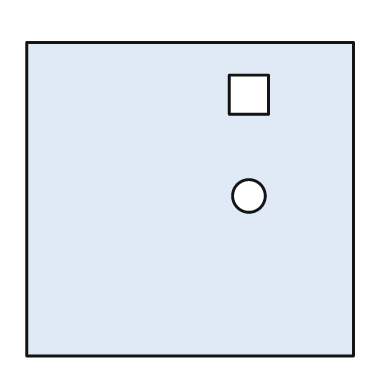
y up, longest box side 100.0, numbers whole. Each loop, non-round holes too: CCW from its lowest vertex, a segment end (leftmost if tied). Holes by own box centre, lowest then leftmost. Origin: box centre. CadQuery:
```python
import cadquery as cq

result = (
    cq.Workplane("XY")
    .moveTo(-50.0, -48.0)
    .lineTo(50.0, -48.0)
    .lineTo(50.0, 48.0)
    .lineTo(-50.0, 48.0)
    .close()
    .moveTo(18.0, 1.0)
    .circle(5.0)
    .moveTo(12.0, 26.0)
    .lineTo(24.0, 26.0)
    .lineTo(24.0, 38.0)
    .lineTo(12.0, 38.0)
    .close()
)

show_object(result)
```